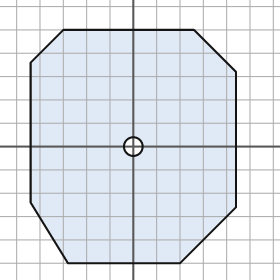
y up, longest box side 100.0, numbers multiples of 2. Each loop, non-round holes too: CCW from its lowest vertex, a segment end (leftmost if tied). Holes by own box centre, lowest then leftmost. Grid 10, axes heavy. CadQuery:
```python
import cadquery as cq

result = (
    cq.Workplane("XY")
    .moveTo(-28.0, -50.0)
    .lineTo(20.0, -50.0)
    .lineTo(44.0, -26.0)
    .lineTo(44.0, 32.0)
    .lineTo(26.0, 50.0)
    .lineTo(-30.0, 50.0)
    .lineTo(-44.0, 36.0)
    .lineTo(-44.0, -24.0)
    .close()
    .moveTo(0.0, 0.0)
    .circle(4.0)
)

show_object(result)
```